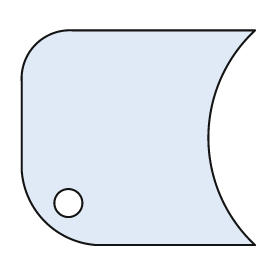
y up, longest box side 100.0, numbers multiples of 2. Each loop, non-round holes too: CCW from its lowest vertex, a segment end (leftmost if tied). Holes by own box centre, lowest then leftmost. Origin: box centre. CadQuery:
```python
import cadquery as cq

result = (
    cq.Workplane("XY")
    .moveTo(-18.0, -46.0)
    .lineTo(50.0, -46.0)
    .threePointArc((30.0, 0.0), (50.0, 46.0))
    .lineTo(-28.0, 46.0)
    .threePointArc((-44.0, 40.0), (-50.0, 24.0))
    .lineTo(-50.0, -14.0)
    .threePointArc((-40.0, -36.0), (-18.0, -46.0))
    .close()
    .moveTo(-30.0, -28.0)
    .circle(6.0)
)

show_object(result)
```